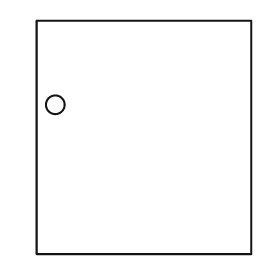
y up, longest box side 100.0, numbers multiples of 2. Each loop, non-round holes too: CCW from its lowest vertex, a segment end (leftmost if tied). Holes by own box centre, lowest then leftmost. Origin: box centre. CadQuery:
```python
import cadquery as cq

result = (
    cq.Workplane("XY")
    .moveTo(-46.0, -50.0)
    .lineTo(46.0, -50.0)
    .lineTo(46.0, 50.0)
    .lineTo(-46.0, 50.0)
    .close()
    .moveTo(-38.0, 14.0)
    .circle(4.0)
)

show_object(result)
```